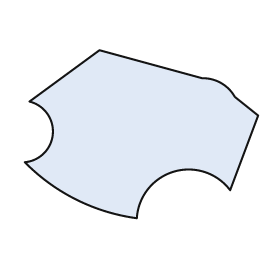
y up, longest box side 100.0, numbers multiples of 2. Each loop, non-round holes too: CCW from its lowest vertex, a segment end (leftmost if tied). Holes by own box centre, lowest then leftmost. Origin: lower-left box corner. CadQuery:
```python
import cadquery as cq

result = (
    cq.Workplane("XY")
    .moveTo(48.0, 0.0)
    .threePointArc((64.0, 20.0), (88.0, 12.0))
    .lineTo(100.0, 44.0)
    .lineTo(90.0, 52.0)
    .threePointArc((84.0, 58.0), (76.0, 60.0))
    .lineTo(32.0, 72.0)
    .lineTo(2.0, 50.0)
    .threePointArc((12.0, 36.0), (0.0, 24.0))
    .threePointArc((22.0, 8.0), (48.0, 0.0))
    .close()
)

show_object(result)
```